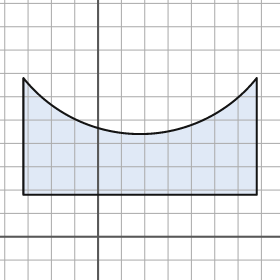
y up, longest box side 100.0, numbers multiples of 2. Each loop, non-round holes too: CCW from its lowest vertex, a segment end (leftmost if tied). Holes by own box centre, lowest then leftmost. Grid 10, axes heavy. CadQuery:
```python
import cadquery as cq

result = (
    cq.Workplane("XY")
    .moveTo(-32.0, 18.0)
    .lineTo(68.0, 18.0)
    .lineTo(68.0, 68.0)
    .threePointArc((18.0, 44.0), (-32.0, 68.0))
    .close()
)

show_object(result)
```